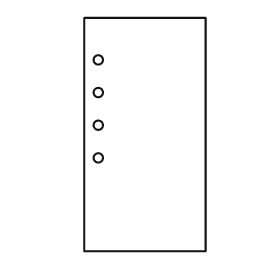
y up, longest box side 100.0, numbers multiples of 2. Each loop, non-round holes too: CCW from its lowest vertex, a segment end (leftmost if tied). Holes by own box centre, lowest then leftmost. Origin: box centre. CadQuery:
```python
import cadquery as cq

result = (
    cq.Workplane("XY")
    .moveTo(-26.0, -50.0)
    .lineTo(26.0, -50.0)
    .lineTo(26.0, 50.0)
    .lineTo(-26.0, 50.0)
    .close()
    .moveTo(-20.0, -10.0)
    .circle(2.0)
    .moveTo(-20.0, 4.0)
    .circle(2.0)
    .moveTo(-20.0, 18.0)
    .circle(2.0)
    .moveTo(-20.0, 32.0)
    .circle(2.0)
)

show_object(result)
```